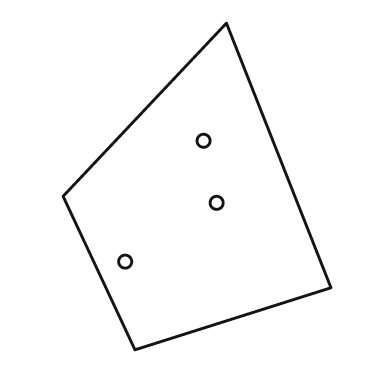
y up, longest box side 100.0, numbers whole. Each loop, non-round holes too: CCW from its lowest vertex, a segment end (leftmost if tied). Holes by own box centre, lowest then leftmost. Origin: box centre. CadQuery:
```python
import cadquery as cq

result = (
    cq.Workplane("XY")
    .moveTo(-19.0, -50.0)
    .lineTo(41.0, -31.0)
    .lineTo(9.0, 50.0)
    .lineTo(-41.0, -3.0)
    .close()
    .moveTo(-22.0, -23.0)
    .circle(2.0)
    .moveTo(6.0, -5.0)
    .circle(2.0)
    .moveTo(2.0, 14.0)
    .circle(2.0)
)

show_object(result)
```